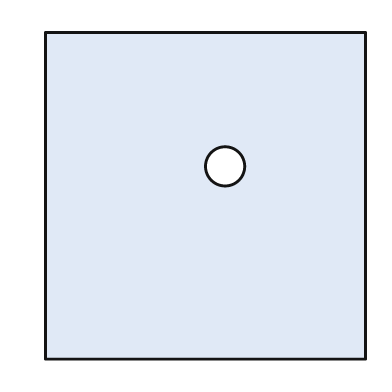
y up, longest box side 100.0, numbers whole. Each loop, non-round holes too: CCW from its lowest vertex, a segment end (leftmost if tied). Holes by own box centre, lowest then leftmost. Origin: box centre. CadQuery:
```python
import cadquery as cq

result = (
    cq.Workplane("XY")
    .moveTo(-49.0, -50.0)
    .lineTo(49.0, -50.0)
    .lineTo(49.0, 50.0)
    .lineTo(-49.0, 50.0)
    .close()
    .moveTo(6.0, 9.0)
    .circle(6.0)
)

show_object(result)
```